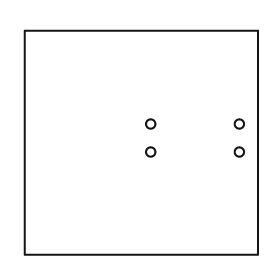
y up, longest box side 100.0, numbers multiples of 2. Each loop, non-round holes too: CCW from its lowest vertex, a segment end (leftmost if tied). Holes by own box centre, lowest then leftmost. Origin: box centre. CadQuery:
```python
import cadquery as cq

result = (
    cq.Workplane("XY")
    .moveTo(-50.0, -48.0)
    .lineTo(50.0, -48.0)
    .lineTo(50.0, 48.0)
    .lineTo(-50.0, 48.0)
    .close()
    .moveTo(4.0, -4.0)
    .circle(2.0)
    .moveTo(42.0, -4.0)
    .circle(2.0)
    .moveTo(4.0, 8.0)
    .circle(2.0)
    .moveTo(42.0, 8.0)
    .circle(2.0)
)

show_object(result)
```